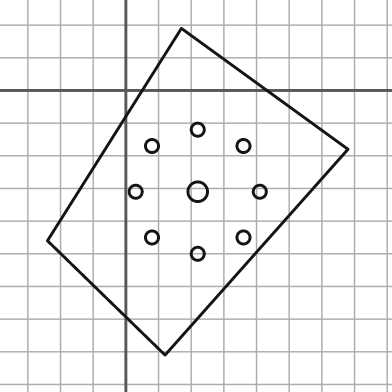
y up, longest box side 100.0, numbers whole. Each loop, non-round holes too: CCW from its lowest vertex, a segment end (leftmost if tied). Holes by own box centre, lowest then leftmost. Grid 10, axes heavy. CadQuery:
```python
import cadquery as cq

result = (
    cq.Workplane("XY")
    .moveTo(12.0, -81.0)
    .lineTo(68.0, -18.0)
    .lineTo(17.0, 19.0)
    .lineTo(-24.0, -46.0)
    .close()
    .moveTo(22.0, -50.0)
    .circle(2.0)
    .moveTo(8.0, -45.0)
    .circle(2.0)
    .moveTo(36.0, -45.0)
    .circle(2.0)
    .moveTo(3.0, -31.0)
    .circle(2.0)
    .moveTo(22.0, -31.0)
    .circle(3.0)
    .moveTo(41.0, -31.0)
    .circle(2.0)
    .moveTo(8.0, -17.0)
    .circle(2.0)
    .moveTo(36.0, -17.0)
    .circle(2.0)
    .moveTo(22.0, -12.0)
    .circle(2.0)
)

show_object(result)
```